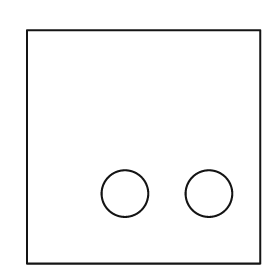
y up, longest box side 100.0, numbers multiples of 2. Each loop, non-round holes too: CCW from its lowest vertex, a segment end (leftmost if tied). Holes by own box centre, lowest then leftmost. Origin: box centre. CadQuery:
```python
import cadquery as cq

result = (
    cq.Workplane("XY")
    .moveTo(-50.0, -50.0)
    .lineTo(50.0, -50.0)
    .lineTo(50.0, 50.0)
    .lineTo(-50.0, 50.0)
    .close()
    .moveTo(-8.0, -20.0)
    .circle(10.0)
    .moveTo(28.0, -20.0)
    .circle(10.0)
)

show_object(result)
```